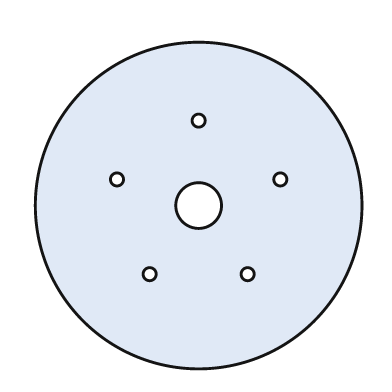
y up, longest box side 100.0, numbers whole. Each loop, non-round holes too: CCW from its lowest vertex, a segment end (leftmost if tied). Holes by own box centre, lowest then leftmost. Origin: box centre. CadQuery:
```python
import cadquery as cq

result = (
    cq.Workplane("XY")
    .moveTo(0.0, 0.0)
    .circle(50.0)
    .moveTo(-15.0, -21.0)
    .circle(2.0)
    .moveTo(15.0, -21.0)
    .circle(2.0)
    .moveTo(0.0, 0.0)
    .circle(7.0)
    .moveTo(-25.0, 8.0)
    .circle(2.0)
    .moveTo(25.0, 8.0)
    .circle(2.0)
    .moveTo(0.0, 26.0)
    .circle(2.0)
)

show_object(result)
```